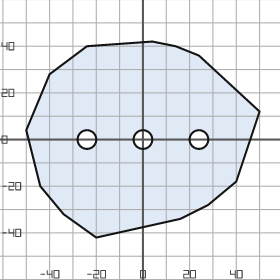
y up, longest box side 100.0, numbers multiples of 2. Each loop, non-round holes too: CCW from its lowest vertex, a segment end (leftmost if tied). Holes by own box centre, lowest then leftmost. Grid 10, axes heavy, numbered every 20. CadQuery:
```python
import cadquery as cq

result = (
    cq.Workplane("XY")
    .moveTo(-20.0, -42.0)
    .lineTo(16.0, -34.0)
    .lineTo(28.0, -28.0)
    .lineTo(40.0, -18.0)
    .lineTo(50.0, 12.0)
    .lineTo(24.0, 36.0)
    .lineTo(14.0, 40.0)
    .lineTo(4.0, 42.0)
    .lineTo(-24.0, 40.0)
    .lineTo(-40.0, 28.0)
    .lineTo(-50.0, 4.0)
    .lineTo(-44.0, -20.0)
    .lineTo(-34.0, -32.0)
    .close()
    .moveTo(-24.0, 0.0)
    .circle(4.0)
    .moveTo(0.0, 0.0)
    .circle(4.0)
    .moveTo(24.0, 0.0)
    .circle(4.0)
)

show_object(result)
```